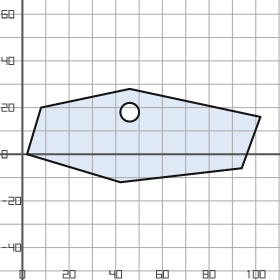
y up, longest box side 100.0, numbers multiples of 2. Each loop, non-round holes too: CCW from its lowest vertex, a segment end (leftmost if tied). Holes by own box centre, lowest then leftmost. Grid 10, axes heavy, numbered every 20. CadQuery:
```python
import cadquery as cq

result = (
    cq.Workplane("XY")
    .moveTo(42.0, -12.0)
    .lineTo(94.0, -6.0)
    .lineTo(102.0, 16.0)
    .lineTo(46.0, 28.0)
    .lineTo(8.0, 20.0)
    .lineTo(2.0, 0.0)
    .close()
    .moveTo(46.0, 18.0)
    .circle(4.0)
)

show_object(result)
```